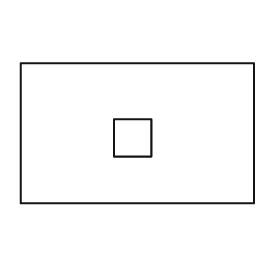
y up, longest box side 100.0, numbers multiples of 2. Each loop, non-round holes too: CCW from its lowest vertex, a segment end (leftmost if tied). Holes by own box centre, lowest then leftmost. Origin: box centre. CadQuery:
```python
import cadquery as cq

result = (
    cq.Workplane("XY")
    .moveTo(-50.0, -30.0)
    .lineTo(50.0, -30.0)
    .lineTo(50.0, 30.0)
    .lineTo(-50.0, 30.0)
    .close()
    .moveTo(-10.0, -10.0)
    .lineTo(6.0, -10.0)
    .lineTo(6.0, 6.0)
    .lineTo(-10.0, 6.0)
    .close()
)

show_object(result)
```